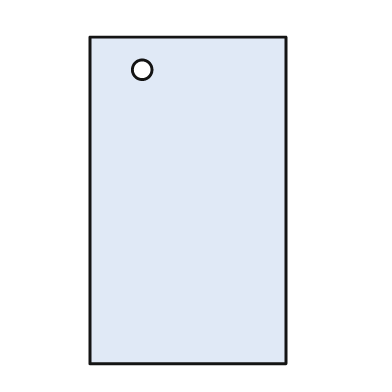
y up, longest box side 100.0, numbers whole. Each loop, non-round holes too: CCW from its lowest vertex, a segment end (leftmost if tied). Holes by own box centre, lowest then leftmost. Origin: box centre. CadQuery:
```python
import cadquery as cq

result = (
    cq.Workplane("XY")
    .moveTo(-30.0, -50.0)
    .lineTo(30.0, -50.0)
    .lineTo(30.0, 50.0)
    .lineTo(-30.0, 50.0)
    .close()
    .moveTo(-14.0, 40.0)
    .circle(3.0)
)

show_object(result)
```